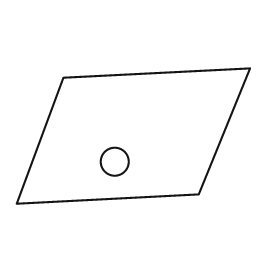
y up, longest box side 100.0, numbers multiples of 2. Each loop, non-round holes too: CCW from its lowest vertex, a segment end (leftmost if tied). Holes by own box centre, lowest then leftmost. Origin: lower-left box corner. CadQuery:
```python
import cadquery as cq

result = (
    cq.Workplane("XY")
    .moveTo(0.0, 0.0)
    .lineTo(78.0, 4.0)
    .lineTo(100.0, 58.0)
    .lineTo(20.0, 54.0)
    .close()
    .moveTo(42.0, 18.0)
    .circle(6.0)
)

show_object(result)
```